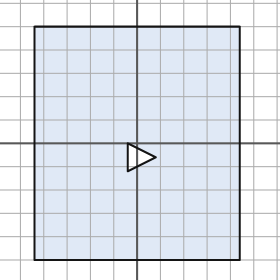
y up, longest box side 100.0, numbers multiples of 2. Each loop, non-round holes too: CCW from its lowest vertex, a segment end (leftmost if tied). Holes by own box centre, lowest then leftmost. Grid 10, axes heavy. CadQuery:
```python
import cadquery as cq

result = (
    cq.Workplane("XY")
    .moveTo(-44.0, -50.0)
    .lineTo(44.0, -50.0)
    .lineTo(44.0, 50.0)
    .lineTo(-44.0, 50.0)
    .close()
    .moveTo(-4.0, -12.0)
    .lineTo(8.0, -6.0)
    .lineTo(-4.0, 0.0)
    .close()
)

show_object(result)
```